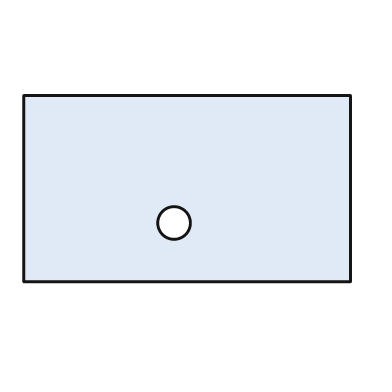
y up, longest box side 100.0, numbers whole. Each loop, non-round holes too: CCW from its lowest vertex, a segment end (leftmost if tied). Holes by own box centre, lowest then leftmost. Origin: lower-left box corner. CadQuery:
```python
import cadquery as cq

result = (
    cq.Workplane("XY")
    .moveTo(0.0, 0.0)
    .lineTo(100.0, 0.0)
    .lineTo(100.0, 57.0)
    .lineTo(0.0, 57.0)
    .close()
    .moveTo(46.0, 18.0)
    .circle(5.0)
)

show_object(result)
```